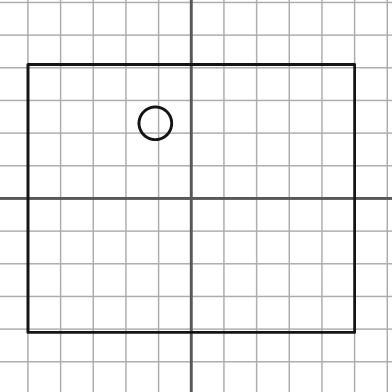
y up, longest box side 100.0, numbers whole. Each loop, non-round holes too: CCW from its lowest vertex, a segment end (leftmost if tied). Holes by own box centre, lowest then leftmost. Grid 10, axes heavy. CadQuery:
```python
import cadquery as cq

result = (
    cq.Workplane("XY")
    .moveTo(-50.0, -41.0)
    .lineTo(50.0, -41.0)
    .lineTo(50.0, 41.0)
    .lineTo(-50.0, 41.0)
    .close()
    .moveTo(-11.0, 23.0)
    .circle(5.0)
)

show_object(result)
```